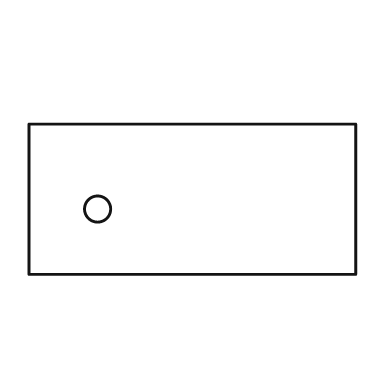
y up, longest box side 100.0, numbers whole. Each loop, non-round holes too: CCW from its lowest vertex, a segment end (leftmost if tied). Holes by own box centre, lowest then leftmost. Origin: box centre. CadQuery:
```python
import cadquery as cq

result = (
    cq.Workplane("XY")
    .moveTo(-50.0, -23.0)
    .lineTo(50.0, -23.0)
    .lineTo(50.0, 23.0)
    .lineTo(-50.0, 23.0)
    .close()
    .moveTo(-29.0, -3.0)
    .circle(4.0)
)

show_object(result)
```